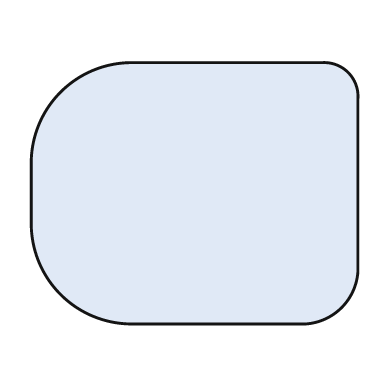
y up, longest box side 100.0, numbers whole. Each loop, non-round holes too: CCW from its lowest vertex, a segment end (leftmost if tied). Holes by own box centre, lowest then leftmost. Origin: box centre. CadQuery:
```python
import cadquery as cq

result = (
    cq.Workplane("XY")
    .moveTo(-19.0, -40.0)
    .lineTo(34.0, -40.0)
    .threePointArc((45.0, -35.0), (50.0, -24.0))
    .lineTo(50.0, 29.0)
    .threePointArc((47.0, 37.0), (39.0, 40.0))
    .lineTo(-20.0, 40.0)
    .threePointArc((-41.0, 31.0), (-50.0, 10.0))
    .lineTo(-50.0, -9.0)
    .threePointArc((-41.0, -31.0), (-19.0, -40.0))
    .close()
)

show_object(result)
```